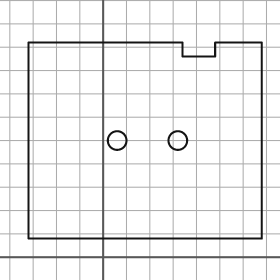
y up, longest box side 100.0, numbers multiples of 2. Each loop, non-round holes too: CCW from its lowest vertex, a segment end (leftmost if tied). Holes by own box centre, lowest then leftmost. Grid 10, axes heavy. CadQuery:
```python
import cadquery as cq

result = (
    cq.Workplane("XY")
    .moveTo(-32.0, 8.0)
    .lineTo(68.0, 8.0)
    .lineTo(68.0, 92.0)
    .lineTo(48.0, 92.0)
    .lineTo(48.0, 86.0)
    .lineTo(34.0, 86.0)
    .lineTo(34.0, 92.0)
    .lineTo(-32.0, 92.0)
    .close()
    .moveTo(6.0, 50.0)
    .circle(4.0)
    .moveTo(32.0, 50.0)
    .circle(4.0)
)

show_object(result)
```